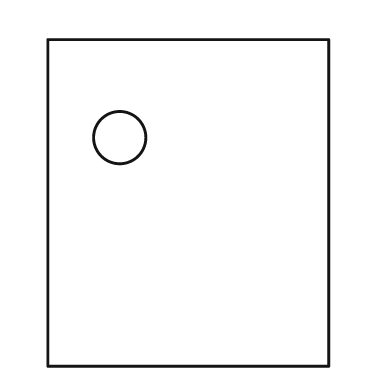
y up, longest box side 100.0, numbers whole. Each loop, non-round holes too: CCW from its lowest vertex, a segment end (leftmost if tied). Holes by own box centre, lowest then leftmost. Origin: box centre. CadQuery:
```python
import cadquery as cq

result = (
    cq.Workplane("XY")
    .moveTo(-43.0, -50.0)
    .lineTo(43.0, -50.0)
    .lineTo(43.0, 50.0)
    .lineTo(-43.0, 50.0)
    .close()
    .moveTo(-21.0, 20.0)
    .circle(8.0)
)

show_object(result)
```